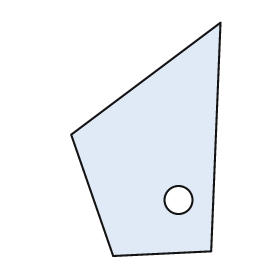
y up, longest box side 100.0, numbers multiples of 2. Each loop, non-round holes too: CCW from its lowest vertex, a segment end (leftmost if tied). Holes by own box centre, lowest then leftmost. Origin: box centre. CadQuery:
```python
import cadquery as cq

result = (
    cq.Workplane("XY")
    .moveTo(-14.0, -50.0)
    .lineTo(28.0, -48.0)
    .lineTo(32.0, 50.0)
    .lineTo(-32.0, 2.0)
    .close()
    .moveTo(14.0, -26.0)
    .circle(6.0)
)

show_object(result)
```